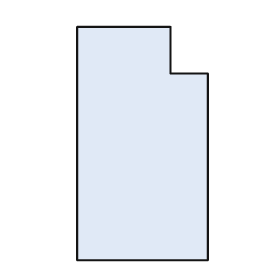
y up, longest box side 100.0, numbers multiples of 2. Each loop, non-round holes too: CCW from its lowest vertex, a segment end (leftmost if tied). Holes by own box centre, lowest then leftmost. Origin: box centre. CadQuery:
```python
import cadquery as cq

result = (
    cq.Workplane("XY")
    .moveTo(-28.0, -50.0)
    .lineTo(28.0, -50.0)
    .lineTo(28.0, 30.0)
    .lineTo(12.0, 30.0)
    .lineTo(12.0, 50.0)
    .lineTo(-28.0, 50.0)
    .close()
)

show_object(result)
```